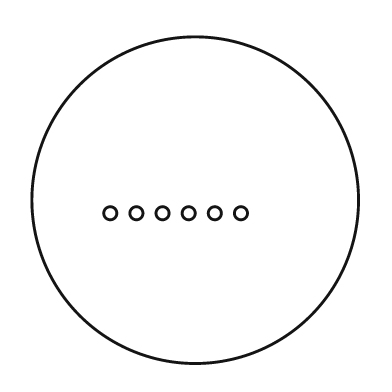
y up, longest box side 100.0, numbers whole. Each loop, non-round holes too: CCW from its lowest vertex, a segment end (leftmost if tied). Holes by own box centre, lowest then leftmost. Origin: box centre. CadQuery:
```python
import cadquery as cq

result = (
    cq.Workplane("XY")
    .moveTo(0.0, 0.0)
    .circle(50.0)
    .moveTo(-26.0, -4.0)
    .circle(2.0)
    .moveTo(-18.0, -4.0)
    .circle(2.0)
    .moveTo(-10.0, -4.0)
    .circle(2.0)
    .moveTo(-2.0, -4.0)
    .circle(2.0)
    .moveTo(6.0, -4.0)
    .circle(2.0)
    .moveTo(14.0, -4.0)
    .circle(2.0)
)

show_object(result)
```